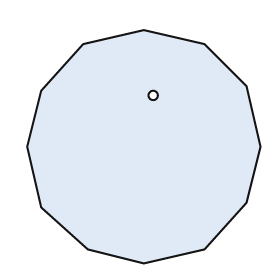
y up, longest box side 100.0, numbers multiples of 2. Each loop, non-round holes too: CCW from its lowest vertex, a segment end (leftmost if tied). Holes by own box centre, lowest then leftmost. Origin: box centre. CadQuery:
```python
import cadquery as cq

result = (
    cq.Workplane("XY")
    .moveTo(0.0, -50.0)
    .lineTo(26.0, -44.0)
    .lineTo(44.0, -24.0)
    .lineTo(50.0, 0.0)
    .lineTo(44.0, 26.0)
    .lineTo(26.0, 44.0)
    .lineTo(0.0, 50.0)
    .lineTo(-26.0, 44.0)
    .lineTo(-44.0, 24.0)
    .lineTo(-50.0, 0.0)
    .lineTo(-44.0, -26.0)
    .lineTo(-24.0, -44.0)
    .close()
    .moveTo(4.0, 22.0)
    .circle(2.0)
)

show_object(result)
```